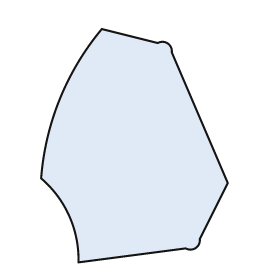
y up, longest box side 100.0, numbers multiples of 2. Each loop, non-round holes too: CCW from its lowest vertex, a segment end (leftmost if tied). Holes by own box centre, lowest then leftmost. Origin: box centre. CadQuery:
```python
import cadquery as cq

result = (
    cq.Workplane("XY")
    .moveTo(-24.0, -50.0)
    .lineTo(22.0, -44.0)
    .threePointArc((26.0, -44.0), (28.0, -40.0))
    .lineTo(40.0, -16.0)
    .lineTo(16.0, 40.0)
    .threePointArc((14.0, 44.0), (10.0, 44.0))
    .lineTo(-14.0, 50.0)
    .threePointArc((-32.0, 20.0), (-40.0, -14.0))
    .threePointArc((-28.0, -30.0), (-24.0, -50.0))
    .close()
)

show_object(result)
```